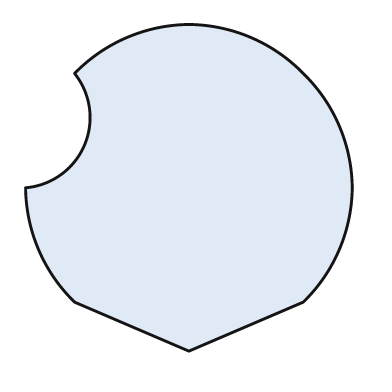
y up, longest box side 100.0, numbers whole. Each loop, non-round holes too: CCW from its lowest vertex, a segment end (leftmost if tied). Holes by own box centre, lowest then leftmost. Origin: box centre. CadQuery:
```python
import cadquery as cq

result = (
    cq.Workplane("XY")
    .moveTo(0.0, -50.0)
    .lineTo(35.0, -35.0)
    .threePointArc((46.0, -19.0), (50.0, 0.0))
    .threePointArc((46.0, 19.0), (35.0, 35.0))
    .threePointArc((19.0, 46.0), (0.0, 50.0))
    .threePointArc((-19.0, 46.0), (-35.0, 35.0))
    .threePointArc((-32.0, 13.0), (-50.0, 0.0))
    .threePointArc((-46.0, -19.0), (-35.0, -35.0))
    .close()
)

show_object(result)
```